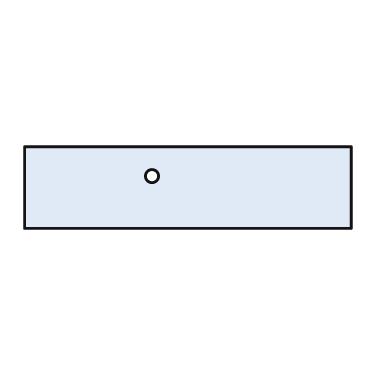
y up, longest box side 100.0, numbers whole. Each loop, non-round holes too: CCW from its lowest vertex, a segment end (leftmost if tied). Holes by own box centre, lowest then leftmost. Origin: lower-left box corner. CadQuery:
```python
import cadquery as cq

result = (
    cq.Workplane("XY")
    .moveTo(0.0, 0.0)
    .lineTo(100.0, 0.0)
    .lineTo(100.0, 25.0)
    .lineTo(0.0, 25.0)
    .close()
    .moveTo(39.0, 16.0)
    .circle(2.0)
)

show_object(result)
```